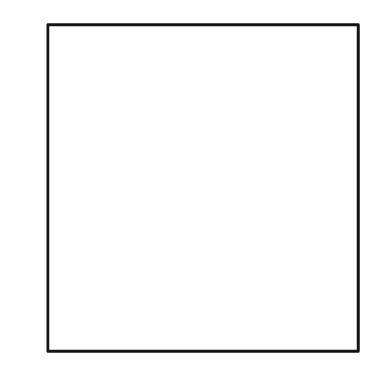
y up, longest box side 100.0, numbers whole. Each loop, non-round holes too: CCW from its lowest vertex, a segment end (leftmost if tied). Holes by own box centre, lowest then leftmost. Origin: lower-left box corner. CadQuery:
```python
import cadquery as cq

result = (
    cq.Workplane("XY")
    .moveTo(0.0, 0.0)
    .lineTo(95.0, 0.0)
    .lineTo(95.0, 100.0)
    .lineTo(0.0, 100.0)
    .close()
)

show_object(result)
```